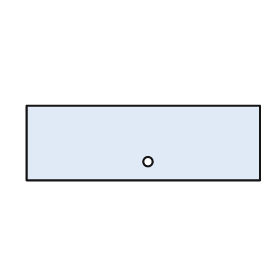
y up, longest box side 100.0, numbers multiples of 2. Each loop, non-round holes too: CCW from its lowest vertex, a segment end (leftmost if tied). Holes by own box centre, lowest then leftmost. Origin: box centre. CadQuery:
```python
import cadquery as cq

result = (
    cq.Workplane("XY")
    .moveTo(-50.0, -16.0)
    .lineTo(50.0, -16.0)
    .lineTo(50.0, 16.0)
    .lineTo(-50.0, 16.0)
    .close()
    .moveTo(2.0, -8.0)
    .circle(2.0)
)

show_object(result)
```